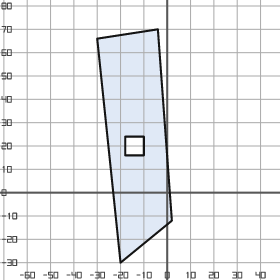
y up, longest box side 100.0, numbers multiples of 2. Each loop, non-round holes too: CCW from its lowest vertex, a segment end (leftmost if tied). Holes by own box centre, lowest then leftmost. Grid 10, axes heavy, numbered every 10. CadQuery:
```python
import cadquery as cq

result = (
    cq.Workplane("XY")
    .moveTo(-20.0, -30.0)
    .lineTo(2.0, -12.0)
    .lineTo(-4.0, 70.0)
    .lineTo(-30.0, 66.0)
    .close()
    .moveTo(-18.0, 16.0)
    .lineTo(-10.0, 16.0)
    .lineTo(-10.0, 24.0)
    .lineTo(-18.0, 24.0)
    .close()
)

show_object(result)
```